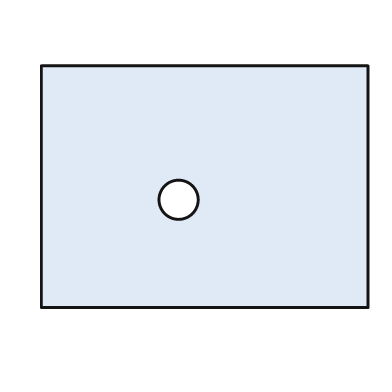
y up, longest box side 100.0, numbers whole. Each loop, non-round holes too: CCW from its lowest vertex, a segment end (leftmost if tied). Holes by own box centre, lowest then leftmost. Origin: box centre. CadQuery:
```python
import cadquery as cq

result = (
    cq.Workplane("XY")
    .moveTo(-50.0, -37.0)
    .lineTo(50.0, -37.0)
    .lineTo(50.0, 37.0)
    .lineTo(-50.0, 37.0)
    .close()
    .moveTo(-8.0, -4.0)
    .circle(6.0)
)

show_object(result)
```